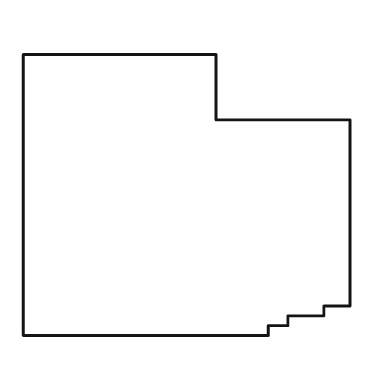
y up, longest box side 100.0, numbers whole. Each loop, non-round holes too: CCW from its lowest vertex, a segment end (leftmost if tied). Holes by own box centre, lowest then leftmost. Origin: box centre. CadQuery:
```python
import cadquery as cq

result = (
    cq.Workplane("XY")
    .moveTo(-50.0, -43.0)
    .lineTo(25.0, -43.0)
    .lineTo(25.0, -40.0)
    .lineTo(31.0, -40.0)
    .lineTo(31.0, -37.0)
    .lineTo(42.0, -37.0)
    .lineTo(42.0, -34.0)
    .lineTo(50.0, -34.0)
    .lineTo(50.0, 23.0)
    .lineTo(9.0, 23.0)
    .lineTo(9.0, 43.0)
    .lineTo(-50.0, 43.0)
    .close()
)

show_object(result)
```